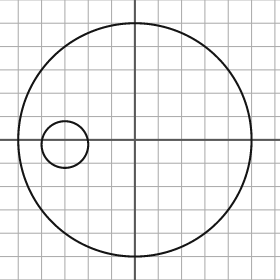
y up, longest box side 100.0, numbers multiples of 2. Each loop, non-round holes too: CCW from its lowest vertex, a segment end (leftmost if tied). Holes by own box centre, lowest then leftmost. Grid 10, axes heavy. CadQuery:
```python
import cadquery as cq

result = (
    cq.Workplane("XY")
    .moveTo(0.0, 0.0)
    .circle(50.0)
    .moveTo(-30.0, -2.0)
    .circle(10.0)
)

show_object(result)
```